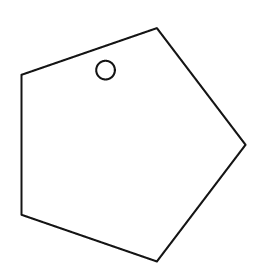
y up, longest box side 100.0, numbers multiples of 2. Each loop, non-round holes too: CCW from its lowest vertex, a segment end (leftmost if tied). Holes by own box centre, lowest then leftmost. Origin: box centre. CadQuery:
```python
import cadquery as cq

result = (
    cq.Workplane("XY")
    .moveTo(10.0, -50.0)
    .lineTo(48.0, 0.0)
    .lineTo(10.0, 50.0)
    .lineTo(-48.0, 30.0)
    .lineTo(-48.0, -30.0)
    .close()
    .moveTo(-12.0, 32.0)
    .circle(4.0)
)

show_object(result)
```